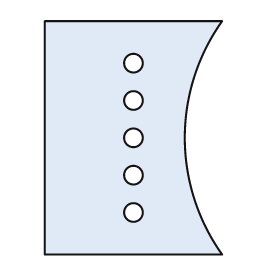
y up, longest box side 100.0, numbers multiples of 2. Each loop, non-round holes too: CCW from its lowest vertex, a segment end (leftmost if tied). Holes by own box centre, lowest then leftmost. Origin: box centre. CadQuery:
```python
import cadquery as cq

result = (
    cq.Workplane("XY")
    .moveTo(-38.0, -50.0)
    .lineTo(38.0, -50.0)
    .threePointArc((22.0, 0.0), (38.0, 50.0))
    .lineTo(-38.0, 50.0)
    .close()
    .moveTo(0.0, -32.0)
    .circle(4.0)
    .moveTo(0.0, -16.0)
    .circle(4.0)
    .moveTo(0.0, 0.0)
    .circle(4.0)
    .moveTo(0.0, 16.0)
    .circle(4.0)
    .moveTo(0.0, 32.0)
    .circle(4.0)
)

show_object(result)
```